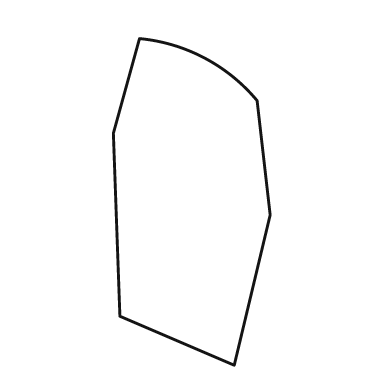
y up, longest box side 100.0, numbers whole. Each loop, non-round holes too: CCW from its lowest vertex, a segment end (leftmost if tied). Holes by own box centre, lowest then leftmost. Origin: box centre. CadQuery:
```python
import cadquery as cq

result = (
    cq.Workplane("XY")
    .moveTo(13.0, -50.0)
    .lineTo(24.0, -4.0)
    .lineTo(20.0, 31.0)
    .threePointArc((4.0, 44.0), (-16.0, 50.0))
    .lineTo(-24.0, 21.0)
    .lineTo(-22.0, -35.0)
    .close()
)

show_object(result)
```